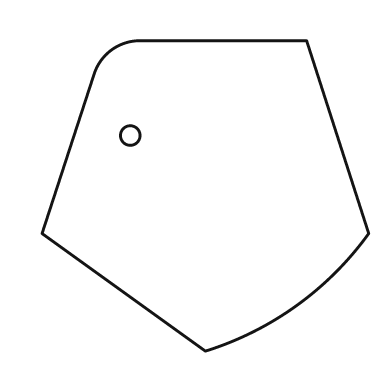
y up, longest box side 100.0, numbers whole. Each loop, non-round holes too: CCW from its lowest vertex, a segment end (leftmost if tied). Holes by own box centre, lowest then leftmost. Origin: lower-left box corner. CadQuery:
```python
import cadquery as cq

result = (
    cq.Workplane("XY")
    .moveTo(50.0, 0.0)
    .threePointArc((78.0, 14.0), (100.0, 36.0))
    .lineTo(81.0, 95.0)
    .lineTo(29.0, 95.0)
    .threePointArc((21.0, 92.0), (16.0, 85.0))
    .lineTo(0.0, 36.0)
    .close()
    .moveTo(27.0, 66.0)
    .circle(3.0)
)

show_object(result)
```